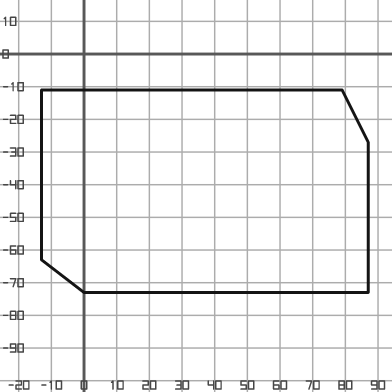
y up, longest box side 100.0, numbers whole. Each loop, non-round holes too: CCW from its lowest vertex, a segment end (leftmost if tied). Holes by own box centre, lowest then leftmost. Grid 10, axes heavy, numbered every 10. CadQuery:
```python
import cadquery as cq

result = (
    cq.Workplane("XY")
    .moveTo(0.0, -73.0)
    .lineTo(87.0, -73.0)
    .lineTo(87.0, -27.0)
    .lineTo(79.0, -11.0)
    .lineTo(-13.0, -11.0)
    .lineTo(-13.0, -63.0)
    .close()
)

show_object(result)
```